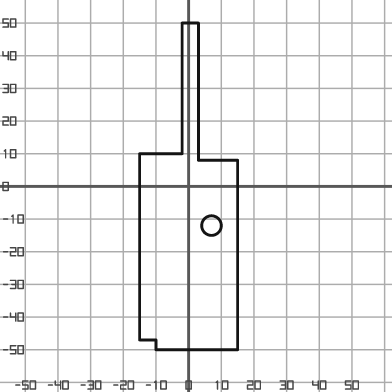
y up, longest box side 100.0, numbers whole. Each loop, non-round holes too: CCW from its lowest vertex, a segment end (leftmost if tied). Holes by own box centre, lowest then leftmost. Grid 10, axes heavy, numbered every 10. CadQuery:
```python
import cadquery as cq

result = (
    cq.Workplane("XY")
    .moveTo(-10.0, -50.0)
    .lineTo(15.0, -50.0)
    .lineTo(15.0, 8.0)
    .lineTo(3.0, 8.0)
    .lineTo(3.0, 50.0)
    .lineTo(-2.0, 50.0)
    .lineTo(-2.0, 10.0)
    .lineTo(-15.0, 10.0)
    .lineTo(-15.0, -47.0)
    .lineTo(-10.0, -47.0)
    .close()
    .moveTo(7.0, -12.0)
    .circle(3.0)
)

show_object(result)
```